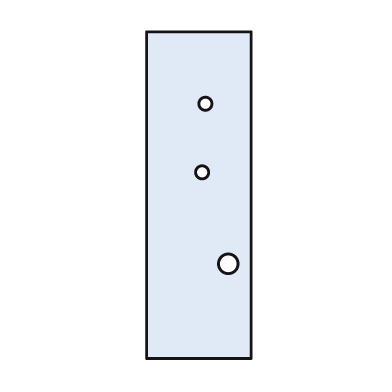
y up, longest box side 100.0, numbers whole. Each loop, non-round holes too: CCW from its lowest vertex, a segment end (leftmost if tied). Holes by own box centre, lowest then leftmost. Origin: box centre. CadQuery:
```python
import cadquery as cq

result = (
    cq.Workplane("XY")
    .moveTo(-16.0, -50.0)
    .lineTo(16.0, -50.0)
    .lineTo(16.0, 50.0)
    .lineTo(-16.0, 50.0)
    .close()
    .moveTo(9.0, -21.0)
    .circle(3.0)
    .moveTo(1.0, 7.0)
    .circle(2.0)
    .moveTo(2.0, 28.0)
    .circle(2.0)
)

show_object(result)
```